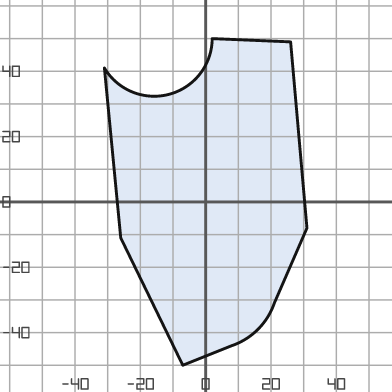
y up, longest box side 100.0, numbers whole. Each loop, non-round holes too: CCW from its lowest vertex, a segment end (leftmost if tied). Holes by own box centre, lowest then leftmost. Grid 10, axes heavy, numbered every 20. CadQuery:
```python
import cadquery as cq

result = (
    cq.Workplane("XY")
    .moveTo(-7.0, -50.0)
    .lineTo(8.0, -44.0)
    .threePointArc((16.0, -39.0), (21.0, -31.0))
    .lineTo(31.0, -8.0)
    .lineTo(26.0, 49.0)
    .lineTo(2.0, 50.0)
    .threePointArc((-11.0, 33.0), (-31.0, 41.0))
    .lineTo(-26.0, -11.0)
    .close()
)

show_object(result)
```